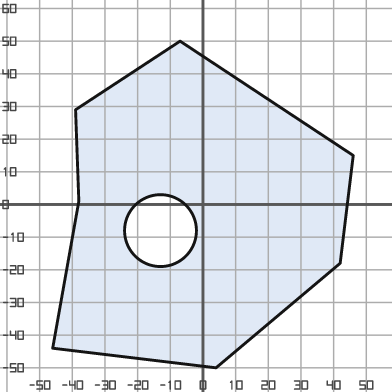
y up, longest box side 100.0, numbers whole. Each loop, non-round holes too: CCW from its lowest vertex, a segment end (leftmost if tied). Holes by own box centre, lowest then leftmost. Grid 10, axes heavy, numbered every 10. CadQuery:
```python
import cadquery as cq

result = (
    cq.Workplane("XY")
    .moveTo(4.0, -50.0)
    .lineTo(42.0, -18.0)
    .lineTo(46.0, 15.0)
    .lineTo(-7.0, 50.0)
    .lineTo(-39.0, 29.0)
    .lineTo(-38.0, 1.0)
    .lineTo(-46.0, -44.0)
    .close()
    .moveTo(-13.0, -8.0)
    .circle(11.0)
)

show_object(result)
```